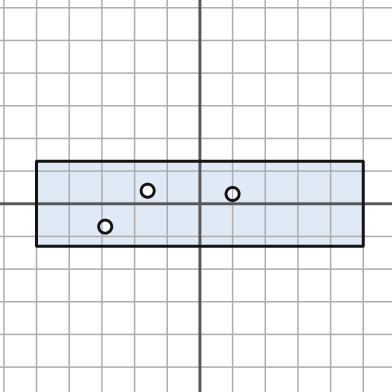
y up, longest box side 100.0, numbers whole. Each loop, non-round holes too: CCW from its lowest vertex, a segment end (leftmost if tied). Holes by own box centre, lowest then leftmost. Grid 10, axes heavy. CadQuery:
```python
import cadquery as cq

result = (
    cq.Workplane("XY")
    .moveTo(-50.0, -13.0)
    .lineTo(50.0, -13.0)
    .lineTo(50.0, 13.0)
    .lineTo(-50.0, 13.0)
    .close()
    .moveTo(-29.0, -7.0)
    .circle(2.0)
    .moveTo(10.0, 3.0)
    .circle(2.0)
    .moveTo(-16.0, 4.0)
    .circle(2.0)
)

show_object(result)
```